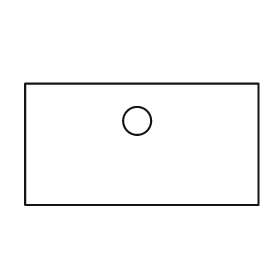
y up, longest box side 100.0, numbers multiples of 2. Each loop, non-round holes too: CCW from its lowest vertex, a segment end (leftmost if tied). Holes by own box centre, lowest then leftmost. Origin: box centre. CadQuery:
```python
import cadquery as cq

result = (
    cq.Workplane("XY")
    .moveTo(-50.0, -26.0)
    .lineTo(50.0, -26.0)
    .lineTo(50.0, 26.0)
    .lineTo(-50.0, 26.0)
    .close()
    .moveTo(-2.0, 10.0)
    .circle(6.0)
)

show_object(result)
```